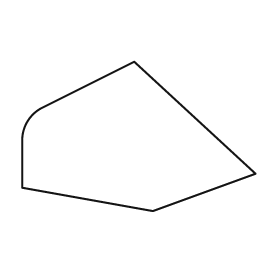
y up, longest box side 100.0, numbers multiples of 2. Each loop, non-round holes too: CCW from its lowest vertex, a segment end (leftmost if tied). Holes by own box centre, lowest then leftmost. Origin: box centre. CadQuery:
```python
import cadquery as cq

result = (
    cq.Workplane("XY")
    .moveTo(6.0, -32.0)
    .lineTo(50.0, -16.0)
    .lineTo(-2.0, 32.0)
    .lineTo(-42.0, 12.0)
    .threePointArc((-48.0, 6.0), (-50.0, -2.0))
    .lineTo(-50.0, -22.0)
    .close()
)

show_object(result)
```